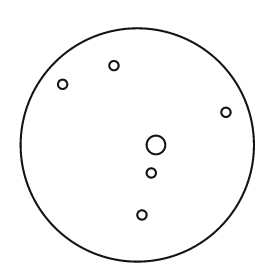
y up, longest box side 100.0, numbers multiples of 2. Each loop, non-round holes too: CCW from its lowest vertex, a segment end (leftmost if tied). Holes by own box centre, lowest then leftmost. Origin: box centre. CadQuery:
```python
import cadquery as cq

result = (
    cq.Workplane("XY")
    .moveTo(0.0, 0.0)
    .circle(50.0)
    .moveTo(2.0, -30.0)
    .circle(2.0)
    .moveTo(6.0, -12.0)
    .circle(2.0)
    .moveTo(8.0, 0.0)
    .circle(4.0)
    .moveTo(38.0, 14.0)
    .circle(2.0)
    .moveTo(-32.0, 26.0)
    .circle(2.0)
    .moveTo(-10.0, 34.0)
    .circle(2.0)
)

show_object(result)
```